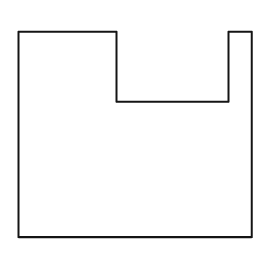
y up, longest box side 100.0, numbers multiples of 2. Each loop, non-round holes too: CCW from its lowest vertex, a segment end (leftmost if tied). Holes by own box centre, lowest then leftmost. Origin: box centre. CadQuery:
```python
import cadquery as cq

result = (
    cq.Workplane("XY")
    .moveTo(-50.0, -44.0)
    .lineTo(50.0, -44.0)
    .lineTo(50.0, 44.0)
    .lineTo(40.0, 44.0)
    .lineTo(40.0, 14.0)
    .lineTo(-8.0, 14.0)
    .lineTo(-8.0, 44.0)
    .lineTo(-50.0, 44.0)
    .close()
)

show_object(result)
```